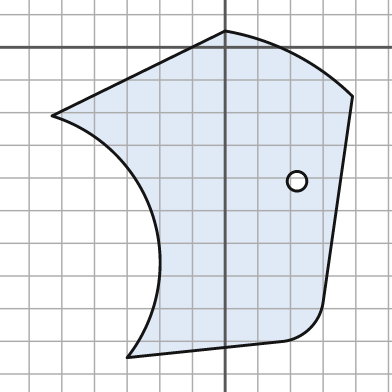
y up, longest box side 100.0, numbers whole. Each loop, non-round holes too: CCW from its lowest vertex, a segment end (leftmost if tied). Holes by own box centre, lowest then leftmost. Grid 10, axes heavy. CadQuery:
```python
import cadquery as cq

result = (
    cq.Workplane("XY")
    .moveTo(-30.0, -95.0)
    .lineTo(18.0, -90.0)
    .threePointArc((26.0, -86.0), (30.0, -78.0))
    .lineTo(39.0, -15.0)
    .threePointArc((21.0, -2.0), (0.0, 5.0))
    .lineTo(-53.0, -21.0)
    .threePointArc((-22.0, -52.0), (-30.0, -95.0))
    .close()
    .moveTo(22.0, -41.0)
    .circle(3.0)
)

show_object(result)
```